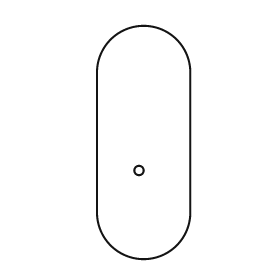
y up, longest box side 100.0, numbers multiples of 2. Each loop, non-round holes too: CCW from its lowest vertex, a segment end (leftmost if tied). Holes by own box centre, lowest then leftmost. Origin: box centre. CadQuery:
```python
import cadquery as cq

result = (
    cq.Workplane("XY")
    .moveTo(-20.0, -30.0)
    .threePointArc((0.0, -50.0), (20.0, -30.0))
    .lineTo(20.0, 30.0)
    .threePointArc((0.0, 50.0), (-20.0, 30.0))
    .close()
    .moveTo(-2.0, -12.0)
    .circle(2.0)
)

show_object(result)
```